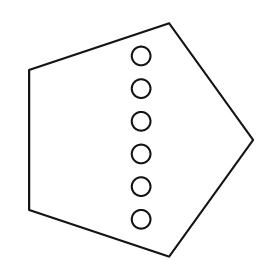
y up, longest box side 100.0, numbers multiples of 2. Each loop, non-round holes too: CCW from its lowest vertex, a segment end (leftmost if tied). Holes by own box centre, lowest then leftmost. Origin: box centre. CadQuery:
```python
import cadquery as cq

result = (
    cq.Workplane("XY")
    .moveTo(12.0, -50.0)
    .lineTo(48.0, 0.0)
    .lineTo(12.0, 50.0)
    .lineTo(-48.0, 30.0)
    .lineTo(-48.0, -30.0)
    .close()
    .moveTo(0.0, -34.0)
    .circle(4.0)
    .moveTo(0.0, -20.0)
    .circle(4.0)
    .moveTo(0.0, -6.0)
    .circle(4.0)
    .moveTo(0.0, 8.0)
    .circle(4.0)
    .moveTo(0.0, 22.0)
    .circle(4.0)
    .moveTo(0.0, 36.0)
    .circle(4.0)
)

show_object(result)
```